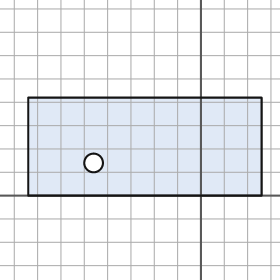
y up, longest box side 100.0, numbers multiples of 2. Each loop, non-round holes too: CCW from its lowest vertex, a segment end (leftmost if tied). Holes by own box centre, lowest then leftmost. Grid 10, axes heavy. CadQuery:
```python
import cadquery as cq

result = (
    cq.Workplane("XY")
    .moveTo(-74.0, 0.0)
    .lineTo(26.0, 0.0)
    .lineTo(26.0, 42.0)
    .lineTo(-74.0, 42.0)
    .close()
    .moveTo(-46.0, 14.0)
    .circle(4.0)
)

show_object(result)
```